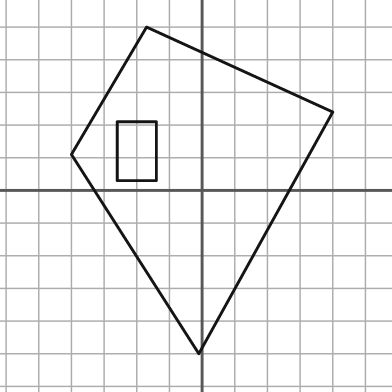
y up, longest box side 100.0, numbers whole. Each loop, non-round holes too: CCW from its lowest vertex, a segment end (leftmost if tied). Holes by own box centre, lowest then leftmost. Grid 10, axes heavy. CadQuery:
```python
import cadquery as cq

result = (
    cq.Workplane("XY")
    .moveTo(-1.0, -50.0)
    .lineTo(40.0, 24.0)
    .lineTo(-17.0, 50.0)
    .lineTo(-40.0, 11.0)
    .close()
    .moveTo(-26.0, 3.0)
    .lineTo(-14.0, 3.0)
    .lineTo(-14.0, 21.0)
    .lineTo(-26.0, 21.0)
    .close()
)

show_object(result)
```